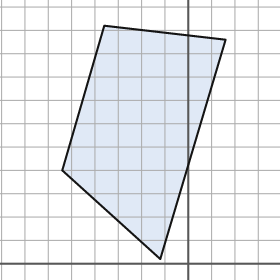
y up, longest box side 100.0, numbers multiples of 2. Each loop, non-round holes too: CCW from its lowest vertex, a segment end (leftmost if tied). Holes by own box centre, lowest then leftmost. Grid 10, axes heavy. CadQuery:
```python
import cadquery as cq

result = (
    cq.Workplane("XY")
    .moveTo(-12.0, 2.0)
    .lineTo(16.0, 96.0)
    .lineTo(-36.0, 102.0)
    .lineTo(-54.0, 40.0)
    .close()
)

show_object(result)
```